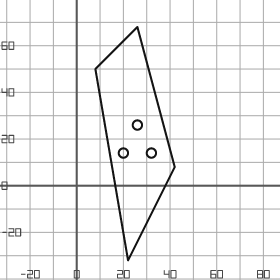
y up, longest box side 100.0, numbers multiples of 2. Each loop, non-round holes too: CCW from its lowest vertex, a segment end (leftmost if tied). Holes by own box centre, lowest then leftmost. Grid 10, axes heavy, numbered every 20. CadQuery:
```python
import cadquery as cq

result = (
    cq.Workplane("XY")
    .moveTo(22.0, -32.0)
    .lineTo(42.0, 8.0)
    .lineTo(26.0, 68.0)
    .lineTo(8.0, 50.0)
    .close()
    .moveTo(20.0, 14.0)
    .circle(2.0)
    .moveTo(32.0, 14.0)
    .circle(2.0)
    .moveTo(26.0, 26.0)
    .circle(2.0)
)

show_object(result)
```